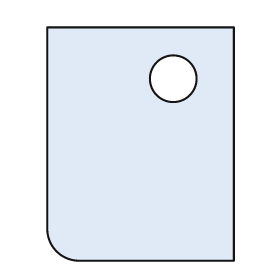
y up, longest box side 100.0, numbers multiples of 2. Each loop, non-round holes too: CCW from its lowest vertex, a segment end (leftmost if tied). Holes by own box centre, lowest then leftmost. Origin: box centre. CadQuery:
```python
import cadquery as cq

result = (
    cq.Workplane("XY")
    .moveTo(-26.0, -50.0)
    .lineTo(40.0, -50.0)
    .lineTo(40.0, 50.0)
    .lineTo(-40.0, 50.0)
    .lineTo(-40.0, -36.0)
    .threePointArc((-36.0, -46.0), (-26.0, -50.0))
    .close()
    .moveTo(14.0, 28.0)
    .circle(10.0)
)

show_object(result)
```